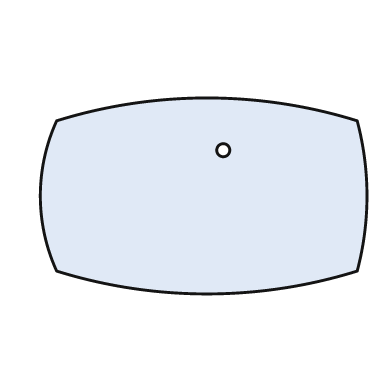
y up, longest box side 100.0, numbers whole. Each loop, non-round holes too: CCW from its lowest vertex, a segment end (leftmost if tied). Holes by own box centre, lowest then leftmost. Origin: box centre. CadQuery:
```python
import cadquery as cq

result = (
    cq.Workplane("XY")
    .moveTo(-45.0, -23.0)
    .threePointArc((1.0, -30.0), (47.0, -23.0))
    .threePointArc((50.0, 0.0), (47.0, 23.0))
    .threePointArc((1.0, 30.0), (-45.0, 23.0))
    .threePointArc((-50.0, 0.0), (-45.0, -23.0))
    .close()
    .moveTo(6.0, 14.0)
    .circle(2.0)
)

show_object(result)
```